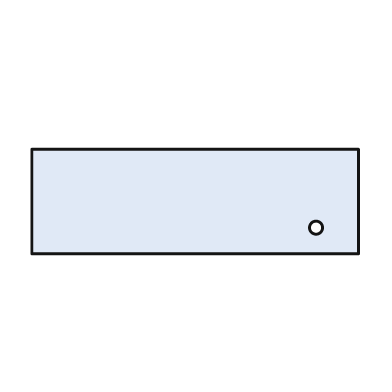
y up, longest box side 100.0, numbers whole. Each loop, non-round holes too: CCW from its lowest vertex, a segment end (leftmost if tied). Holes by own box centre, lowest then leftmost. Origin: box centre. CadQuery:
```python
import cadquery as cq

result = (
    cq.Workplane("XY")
    .moveTo(-50.0, -16.0)
    .lineTo(50.0, -16.0)
    .lineTo(50.0, 16.0)
    .lineTo(-50.0, 16.0)
    .close()
    .moveTo(37.0, -8.0)
    .circle(2.0)
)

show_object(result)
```